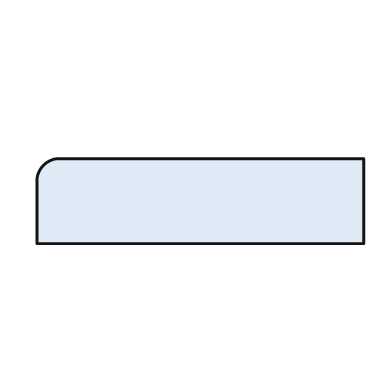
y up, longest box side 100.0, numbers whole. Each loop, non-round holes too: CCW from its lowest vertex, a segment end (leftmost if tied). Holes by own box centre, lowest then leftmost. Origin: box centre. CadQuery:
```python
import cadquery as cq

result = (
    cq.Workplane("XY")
    .moveTo(-50.0, -13.0)
    .lineTo(50.0, -13.0)
    .lineTo(50.0, 13.0)
    .lineTo(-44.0, 13.0)
    .threePointArc((-48.0, 11.0), (-50.0, 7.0))
    .close()
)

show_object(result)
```